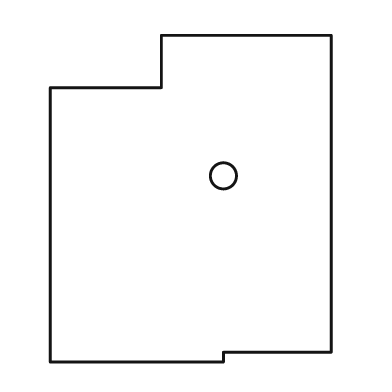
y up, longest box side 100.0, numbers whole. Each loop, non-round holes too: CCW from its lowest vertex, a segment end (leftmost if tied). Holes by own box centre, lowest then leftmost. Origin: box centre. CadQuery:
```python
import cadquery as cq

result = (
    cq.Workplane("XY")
    .moveTo(-43.0, -50.0)
    .lineTo(10.0, -50.0)
    .lineTo(10.0, -47.0)
    .lineTo(43.0, -47.0)
    .lineTo(43.0, 50.0)
    .lineTo(-9.0, 50.0)
    .lineTo(-9.0, 34.0)
    .lineTo(-43.0, 34.0)
    .close()
    .moveTo(10.0, 7.0)
    .circle(4.0)
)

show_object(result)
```